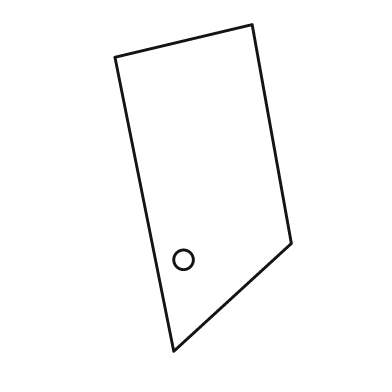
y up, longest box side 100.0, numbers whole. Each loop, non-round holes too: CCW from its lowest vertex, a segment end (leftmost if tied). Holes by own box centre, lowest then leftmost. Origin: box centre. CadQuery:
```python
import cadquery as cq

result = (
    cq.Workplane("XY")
    .moveTo(-9.0, -50.0)
    .lineTo(27.0, -17.0)
    .lineTo(15.0, 50.0)
    .lineTo(-27.0, 40.0)
    .close()
    .moveTo(-6.0, -22.0)
    .circle(3.0)
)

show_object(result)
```